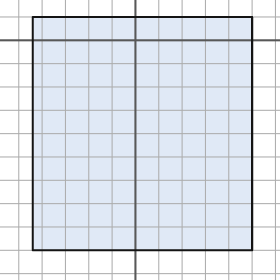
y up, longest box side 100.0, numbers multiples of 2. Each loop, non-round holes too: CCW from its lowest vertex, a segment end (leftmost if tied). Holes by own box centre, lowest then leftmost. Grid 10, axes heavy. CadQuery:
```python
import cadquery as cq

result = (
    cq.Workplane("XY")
    .moveTo(-44.0, -90.0)
    .lineTo(50.0, -90.0)
    .lineTo(50.0, 10.0)
    .lineTo(-44.0, 10.0)
    .close()
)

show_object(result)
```